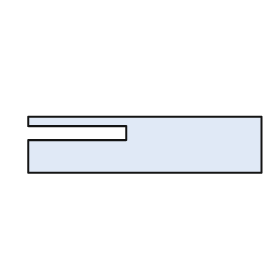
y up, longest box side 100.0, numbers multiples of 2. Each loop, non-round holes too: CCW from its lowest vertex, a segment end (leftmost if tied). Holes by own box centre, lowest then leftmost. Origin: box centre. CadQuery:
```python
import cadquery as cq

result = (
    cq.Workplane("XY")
    .moveTo(-50.0, -12.0)
    .lineTo(50.0, -12.0)
    .lineTo(50.0, 12.0)
    .lineTo(-50.0, 12.0)
    .lineTo(-50.0, 8.0)
    .lineTo(-8.0, 8.0)
    .lineTo(-8.0, 2.0)
    .lineTo(-50.0, 2.0)
    .close()
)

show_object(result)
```